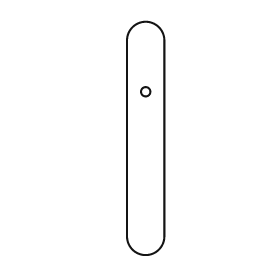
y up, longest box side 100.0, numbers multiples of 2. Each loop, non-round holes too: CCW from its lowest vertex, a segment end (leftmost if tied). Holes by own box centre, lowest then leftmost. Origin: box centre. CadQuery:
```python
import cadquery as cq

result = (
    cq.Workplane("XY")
    .moveTo(-8.0, -42.0)
    .threePointArc((0.0, -50.0), (8.0, -42.0))
    .lineTo(8.0, 42.0)
    .threePointArc((0.0, 50.0), (-8.0, 42.0))
    .close()
    .moveTo(0.0, 20.0)
    .circle(2.0)
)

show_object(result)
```